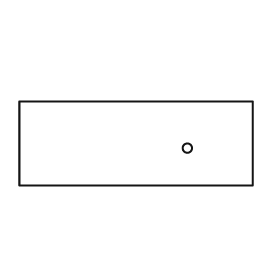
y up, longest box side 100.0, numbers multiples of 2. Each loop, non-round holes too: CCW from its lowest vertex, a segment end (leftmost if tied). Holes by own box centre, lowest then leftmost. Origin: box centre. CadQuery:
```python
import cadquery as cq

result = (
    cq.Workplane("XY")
    .moveTo(-50.0, -18.0)
    .lineTo(50.0, -18.0)
    .lineTo(50.0, 18.0)
    .lineTo(-50.0, 18.0)
    .close()
    .moveTo(22.0, -2.0)
    .circle(2.0)
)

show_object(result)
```